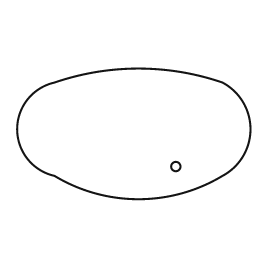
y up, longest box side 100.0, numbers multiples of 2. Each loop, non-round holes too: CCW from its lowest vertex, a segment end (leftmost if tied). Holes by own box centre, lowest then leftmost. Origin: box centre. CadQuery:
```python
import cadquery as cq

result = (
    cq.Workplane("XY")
    .moveTo(-34.0, -18.0)
    .threePointArc((2.0, -28.0), (38.0, -18.0))
    .threePointArc((50.0, 2.0), (38.0, 22.0))
    .threePointArc((2.0, 28.0), (-34.0, 22.0))
    .threePointArc((-50.0, 2.0), (-34.0, -18.0))
    .close()
    .moveTo(18.0, -14.0)
    .circle(2.0)
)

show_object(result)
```